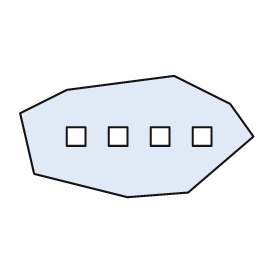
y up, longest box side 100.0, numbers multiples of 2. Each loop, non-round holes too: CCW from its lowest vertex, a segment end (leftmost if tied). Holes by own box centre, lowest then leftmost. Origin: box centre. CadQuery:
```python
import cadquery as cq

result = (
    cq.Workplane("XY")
    .moveTo(-4.0, -26.0)
    .lineTo(22.0, -24.0)
    .lineTo(50.0, 0.0)
    .lineTo(40.0, 14.0)
    .lineTo(16.0, 26.0)
    .lineTo(-30.0, 20.0)
    .lineTo(-50.0, 10.0)
    .lineTo(-44.0, -16.0)
    .close()
    .moveTo(-30.0, -4.0)
    .lineTo(-22.0, -4.0)
    .lineTo(-22.0, 4.0)
    .lineTo(-30.0, 4.0)
    .close()
    .moveTo(-12.0, -4.0)
    .lineTo(-4.0, -4.0)
    .lineTo(-4.0, 4.0)
    .lineTo(-12.0, 4.0)
    .close()
    .moveTo(6.0, -4.0)
    .lineTo(14.0, -4.0)
    .lineTo(14.0, 4.0)
    .lineTo(6.0, 4.0)
    .close()
    .moveTo(24.0, -4.0)
    .lineTo(32.0, -4.0)
    .lineTo(32.0, 4.0)
    .lineTo(24.0, 4.0)
    .close()
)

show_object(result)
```